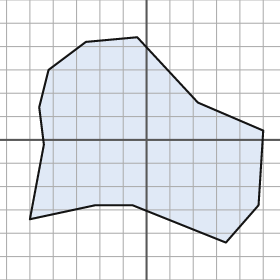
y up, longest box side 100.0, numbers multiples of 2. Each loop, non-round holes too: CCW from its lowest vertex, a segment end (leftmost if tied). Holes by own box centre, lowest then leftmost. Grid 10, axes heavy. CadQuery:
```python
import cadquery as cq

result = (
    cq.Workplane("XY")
    .moveTo(34.0, -44.0)
    .lineTo(48.0, -28.0)
    .lineTo(50.0, 4.0)
    .lineTo(22.0, 16.0)
    .lineTo(-4.0, 44.0)
    .lineTo(-26.0, 42.0)
    .lineTo(-42.0, 30.0)
    .lineTo(-46.0, 14.0)
    .lineTo(-44.0, -2.0)
    .lineTo(-50.0, -34.0)
    .lineTo(-22.0, -28.0)
    .lineTo(-6.0, -28.0)
    .close()
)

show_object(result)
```